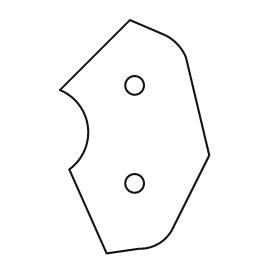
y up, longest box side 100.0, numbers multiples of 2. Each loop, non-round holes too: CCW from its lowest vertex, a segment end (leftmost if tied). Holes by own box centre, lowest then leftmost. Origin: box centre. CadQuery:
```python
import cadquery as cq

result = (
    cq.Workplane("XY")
    .moveTo(-12.0, -50.0)
    .lineTo(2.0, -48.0)
    .threePointArc((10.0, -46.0), (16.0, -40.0))
    .lineTo(32.0, -8.0)
    .lineTo(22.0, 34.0)
    .threePointArc((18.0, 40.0), (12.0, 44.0))
    .lineTo(-2.0, 50.0)
    .lineTo(-32.0, 20.0)
    .threePointArc((-20.0, 4.0), (-28.0, -14.0))
    .close()
    .moveTo(0.0, -20.0)
    .circle(4.0)
    .moveTo(0.0, 22.0)
    .circle(4.0)
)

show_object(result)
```